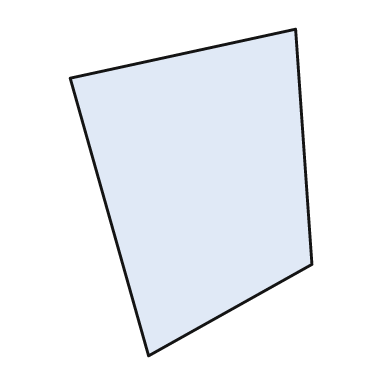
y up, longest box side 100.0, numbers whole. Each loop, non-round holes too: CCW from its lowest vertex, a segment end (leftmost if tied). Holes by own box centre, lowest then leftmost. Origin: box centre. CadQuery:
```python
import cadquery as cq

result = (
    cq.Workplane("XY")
    .moveTo(-13.0, -50.0)
    .lineTo(37.0, -22.0)
    .lineTo(32.0, 50.0)
    .lineTo(-37.0, 35.0)
    .close()
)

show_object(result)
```